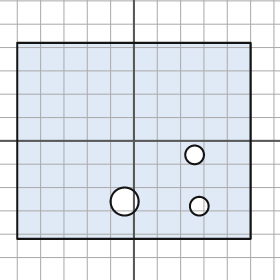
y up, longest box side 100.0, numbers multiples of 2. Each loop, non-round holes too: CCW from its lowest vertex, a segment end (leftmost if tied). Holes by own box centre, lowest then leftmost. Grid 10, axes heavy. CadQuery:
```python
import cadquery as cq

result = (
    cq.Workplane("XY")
    .moveTo(-50.0, -42.0)
    .lineTo(50.0, -42.0)
    .lineTo(50.0, 42.0)
    .lineTo(-50.0, 42.0)
    .close()
    .moveTo(28.0, -28.0)
    .circle(4.0)
    .moveTo(-4.0, -26.0)
    .circle(6.0)
    .moveTo(26.0, -6.0)
    .circle(4.0)
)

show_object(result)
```